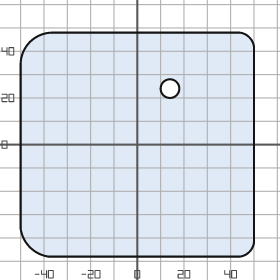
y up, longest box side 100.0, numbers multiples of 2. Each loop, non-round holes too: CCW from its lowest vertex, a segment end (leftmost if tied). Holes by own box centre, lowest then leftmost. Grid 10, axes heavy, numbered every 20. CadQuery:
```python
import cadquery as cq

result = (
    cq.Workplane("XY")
    .moveTo(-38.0, -48.0)
    .lineTo(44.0, -48.0)
    .threePointArc((48.0, -46.0), (50.0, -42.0))
    .lineTo(50.0, 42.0)
    .threePointArc((48.0, 46.0), (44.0, 48.0))
    .lineTo(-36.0, 48.0)
    .threePointArc((-46.0, 44.0), (-50.0, 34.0))
    .lineTo(-50.0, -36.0)
    .threePointArc((-46.0, -44.0), (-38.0, -48.0))
    .close()
    .moveTo(14.0, 24.0)
    .circle(4.0)
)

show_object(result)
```